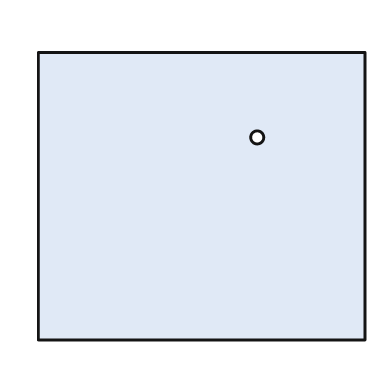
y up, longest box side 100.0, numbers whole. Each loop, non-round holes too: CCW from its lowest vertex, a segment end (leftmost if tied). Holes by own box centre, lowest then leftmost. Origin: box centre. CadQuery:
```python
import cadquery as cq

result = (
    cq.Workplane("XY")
    .moveTo(-50.0, -44.0)
    .lineTo(50.0, -44.0)
    .lineTo(50.0, 44.0)
    .lineTo(-50.0, 44.0)
    .close()
    .moveTo(17.0, 18.0)
    .circle(2.0)
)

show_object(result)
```